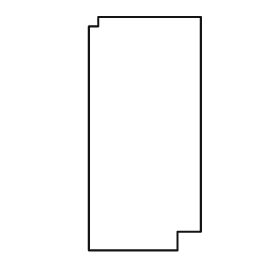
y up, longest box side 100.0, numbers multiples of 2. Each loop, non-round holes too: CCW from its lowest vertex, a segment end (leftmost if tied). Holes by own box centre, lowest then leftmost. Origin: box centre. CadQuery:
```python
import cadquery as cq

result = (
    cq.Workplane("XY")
    .moveTo(-24.0, -50.0)
    .lineTo(14.0, -50.0)
    .lineTo(14.0, -42.0)
    .lineTo(24.0, -42.0)
    .lineTo(24.0, 50.0)
    .lineTo(-20.0, 50.0)
    .lineTo(-20.0, 46.0)
    .lineTo(-24.0, 46.0)
    .close()
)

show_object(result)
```